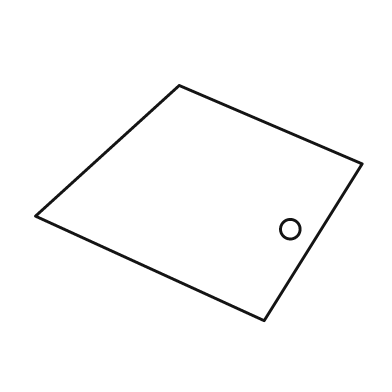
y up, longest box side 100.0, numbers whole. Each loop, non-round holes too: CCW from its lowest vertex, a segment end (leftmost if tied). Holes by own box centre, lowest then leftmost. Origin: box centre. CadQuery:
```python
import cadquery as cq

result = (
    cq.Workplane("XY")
    .moveTo(20.0, -36.0)
    .lineTo(50.0, 12.0)
    .lineTo(-6.0, 36.0)
    .lineTo(-50.0, -4.0)
    .close()
    .moveTo(28.0, -8.0)
    .circle(3.0)
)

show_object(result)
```